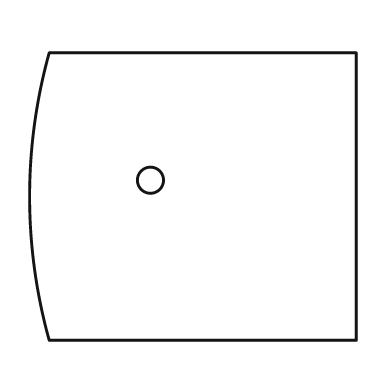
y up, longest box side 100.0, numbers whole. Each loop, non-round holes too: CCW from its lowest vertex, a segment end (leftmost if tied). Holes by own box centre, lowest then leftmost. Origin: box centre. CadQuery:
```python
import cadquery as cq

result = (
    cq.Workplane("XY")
    .moveTo(-44.0, -44.0)
    .lineTo(50.0, -44.0)
    .lineTo(50.0, 44.0)
    .lineTo(-44.0, 44.0)
    .threePointArc((-50.0, 0.0), (-44.0, -44.0))
    .close()
    .moveTo(-13.0, 5.0)
    .circle(4.0)
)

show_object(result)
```